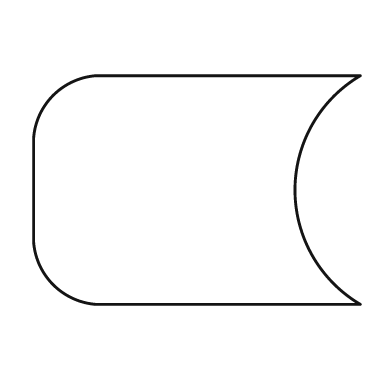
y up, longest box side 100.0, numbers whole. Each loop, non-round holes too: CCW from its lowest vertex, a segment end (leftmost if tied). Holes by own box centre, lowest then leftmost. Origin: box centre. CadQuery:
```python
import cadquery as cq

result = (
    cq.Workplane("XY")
    .moveTo(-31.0, -35.0)
    .lineTo(50.0, -35.0)
    .threePointArc((30.0, 0.0), (50.0, 35.0))
    .lineTo(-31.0, 35.0)
    .threePointArc((-44.0, 29.0), (-50.0, 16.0))
    .lineTo(-50.0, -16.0)
    .threePointArc((-44.0, -29.0), (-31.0, -35.0))
    .close()
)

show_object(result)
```